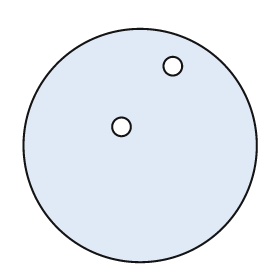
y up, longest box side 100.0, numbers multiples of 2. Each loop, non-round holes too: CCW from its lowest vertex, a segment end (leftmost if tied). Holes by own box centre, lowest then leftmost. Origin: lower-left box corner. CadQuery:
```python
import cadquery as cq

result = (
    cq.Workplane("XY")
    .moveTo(50.0, 50.0)
    .circle(50.0)
    .moveTo(42.0, 58.0)
    .circle(4.0)
    .moveTo(64.0, 84.0)
    .circle(4.0)
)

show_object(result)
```